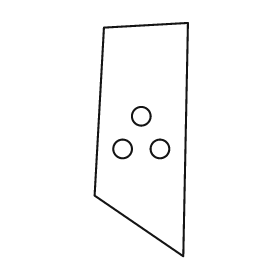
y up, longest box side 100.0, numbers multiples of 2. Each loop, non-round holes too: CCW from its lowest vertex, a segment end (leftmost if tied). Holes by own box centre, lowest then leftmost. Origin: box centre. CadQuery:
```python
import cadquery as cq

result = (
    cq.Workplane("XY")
    .moveTo(18.0, -50.0)
    .lineTo(20.0, 50.0)
    .lineTo(-16.0, 48.0)
    .lineTo(-20.0, -24.0)
    .close()
    .moveTo(-8.0, -4.0)
    .circle(4.0)
    .moveTo(8.0, -4.0)
    .circle(4.0)
    .moveTo(0.0, 10.0)
    .circle(4.0)
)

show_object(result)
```